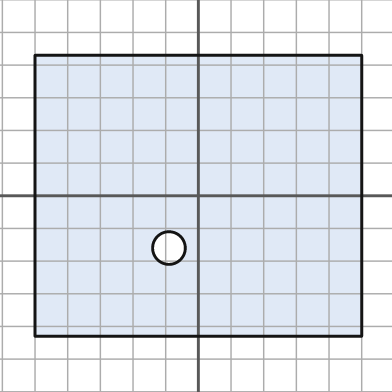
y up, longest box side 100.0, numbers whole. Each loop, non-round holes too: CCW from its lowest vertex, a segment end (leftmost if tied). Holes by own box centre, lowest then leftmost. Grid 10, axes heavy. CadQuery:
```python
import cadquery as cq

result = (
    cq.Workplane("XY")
    .moveTo(-50.0, -43.0)
    .lineTo(50.0, -43.0)
    .lineTo(50.0, 43.0)
    .lineTo(-50.0, 43.0)
    .close()
    .moveTo(-9.0, -16.0)
    .circle(5.0)
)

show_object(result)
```